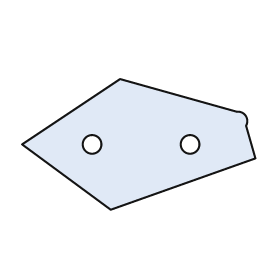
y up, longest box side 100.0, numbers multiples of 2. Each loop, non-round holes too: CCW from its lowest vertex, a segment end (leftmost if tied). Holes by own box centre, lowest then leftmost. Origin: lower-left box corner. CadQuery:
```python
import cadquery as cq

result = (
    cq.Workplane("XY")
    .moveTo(38.0, 0.0)
    .lineTo(100.0, 22.0)
    .lineTo(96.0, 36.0)
    .threePointArc((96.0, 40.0), (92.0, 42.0))
    .lineTo(42.0, 56.0)
    .lineTo(0.0, 28.0)
    .close()
    .moveTo(30.0, 28.0)
    .circle(4.0)
    .moveTo(72.0, 28.0)
    .circle(4.0)
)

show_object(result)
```